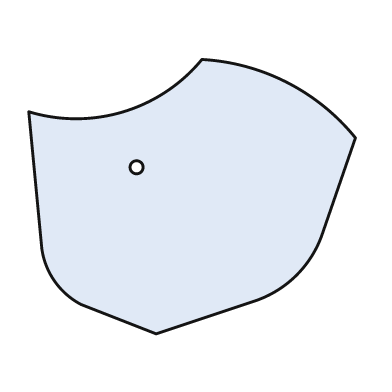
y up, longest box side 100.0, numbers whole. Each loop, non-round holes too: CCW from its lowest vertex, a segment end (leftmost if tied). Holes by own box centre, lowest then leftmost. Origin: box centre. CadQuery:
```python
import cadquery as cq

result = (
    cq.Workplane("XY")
    .moveTo(-11.0, -42.0)
    .lineTo(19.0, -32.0)
    .threePointArc((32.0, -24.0), (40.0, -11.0))
    .lineTo(50.0, 18.0)
    .threePointArc((29.0, 35.0), (3.0, 42.0))
    .threePointArc((-21.0, 26.0), (-50.0, 26.0))
    .lineTo(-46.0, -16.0)
    .threePointArc((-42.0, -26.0), (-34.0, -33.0))
    .close()
    .moveTo(-17.0, 9.0)
    .circle(2.0)
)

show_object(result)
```